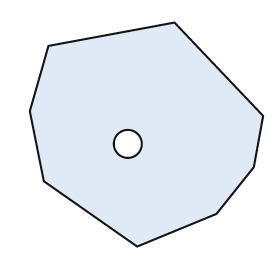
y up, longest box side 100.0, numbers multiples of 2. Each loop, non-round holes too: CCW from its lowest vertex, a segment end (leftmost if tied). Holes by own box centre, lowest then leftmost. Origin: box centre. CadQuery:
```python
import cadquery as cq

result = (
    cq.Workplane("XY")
    .moveTo(-4.0, -48.0)
    .lineTo(30.0, -34.0)
    .lineTo(46.0, -14.0)
    .lineTo(50.0, 8.0)
    .lineTo(12.0, 48.0)
    .lineTo(-42.0, 38.0)
    .lineTo(-50.0, 10.0)
    .lineTo(-44.0, -20.0)
    .close()
    .moveTo(-8.0, -4.0)
    .circle(6.0)
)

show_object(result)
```